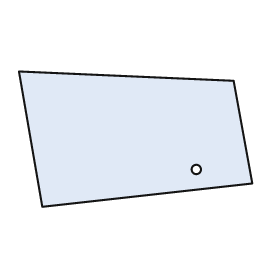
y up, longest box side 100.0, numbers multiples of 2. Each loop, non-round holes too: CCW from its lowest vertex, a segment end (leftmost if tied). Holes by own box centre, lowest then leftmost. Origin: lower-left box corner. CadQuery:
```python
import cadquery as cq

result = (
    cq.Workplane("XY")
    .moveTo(10.0, 0.0)
    .lineTo(100.0, 10.0)
    .lineTo(92.0, 54.0)
    .lineTo(0.0, 58.0)
    .close()
    .moveTo(76.0, 16.0)
    .circle(2.0)
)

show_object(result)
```